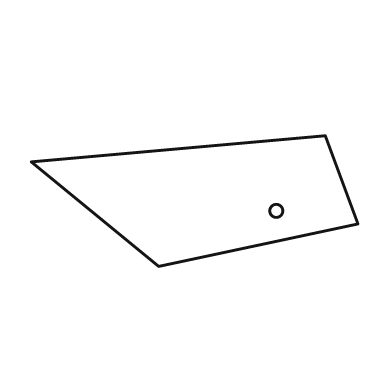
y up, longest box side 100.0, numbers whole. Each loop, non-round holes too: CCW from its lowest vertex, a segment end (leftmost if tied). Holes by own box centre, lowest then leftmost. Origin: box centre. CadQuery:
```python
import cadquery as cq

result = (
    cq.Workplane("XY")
    .moveTo(-11.0, -20.0)
    .lineTo(50.0, -7.0)
    .lineTo(40.0, 20.0)
    .lineTo(-50.0, 12.0)
    .close()
    .moveTo(25.0, -3.0)
    .circle(2.0)
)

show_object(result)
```